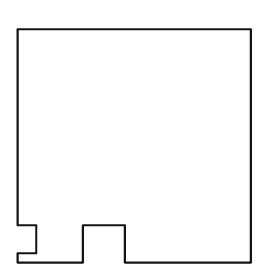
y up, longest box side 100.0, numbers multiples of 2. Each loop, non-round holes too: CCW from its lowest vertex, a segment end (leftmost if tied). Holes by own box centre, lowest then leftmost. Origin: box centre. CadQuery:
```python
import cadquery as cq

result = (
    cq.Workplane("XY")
    .moveTo(-50.0, -50.0)
    .lineTo(-22.0, -50.0)
    .lineTo(-22.0, -34.0)
    .lineTo(-4.0, -34.0)
    .lineTo(-4.0, -50.0)
    .lineTo(50.0, -50.0)
    .lineTo(50.0, 50.0)
    .lineTo(-50.0, 50.0)
    .lineTo(-50.0, -34.0)
    .lineTo(-42.0, -34.0)
    .lineTo(-42.0, -46.0)
    .lineTo(-50.0, -46.0)
    .close()
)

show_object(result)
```